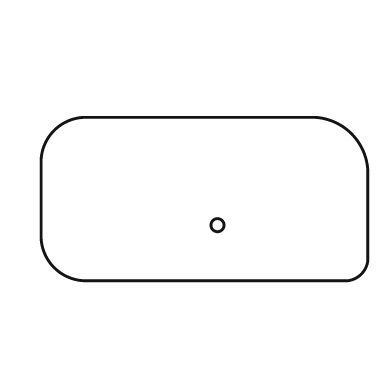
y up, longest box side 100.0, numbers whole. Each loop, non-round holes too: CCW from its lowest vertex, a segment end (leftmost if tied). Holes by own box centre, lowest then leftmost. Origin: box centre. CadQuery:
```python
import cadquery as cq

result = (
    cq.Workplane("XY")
    .moveTo(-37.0, -25.0)
    .lineTo(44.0, -25.0)
    .threePointArc((48.0, -23.0), (50.0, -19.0))
    .lineTo(50.0, 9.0)
    .threePointArc((45.0, 20.0), (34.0, 25.0))
    .lineTo(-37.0, 25.0)
    .threePointArc((-46.0, 21.0), (-50.0, 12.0))
    .lineTo(-50.0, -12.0)
    .threePointArc((-46.0, -21.0), (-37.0, -25.0))
    .close()
    .moveTo(4.0, -8.0)
    .circle(2.0)
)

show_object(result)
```